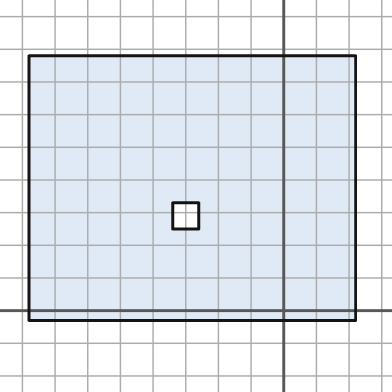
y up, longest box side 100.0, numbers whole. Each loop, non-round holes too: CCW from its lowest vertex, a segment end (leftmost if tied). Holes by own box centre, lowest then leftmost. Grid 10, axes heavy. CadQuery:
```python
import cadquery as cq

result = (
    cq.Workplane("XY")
    .moveTo(-78.0, -3.0)
    .lineTo(22.0, -3.0)
    .lineTo(22.0, 78.0)
    .lineTo(-78.0, 78.0)
    .close()
    .moveTo(-34.0, 25.0)
    .lineTo(-26.0, 25.0)
    .lineTo(-26.0, 33.0)
    .lineTo(-34.0, 33.0)
    .close()
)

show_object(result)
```